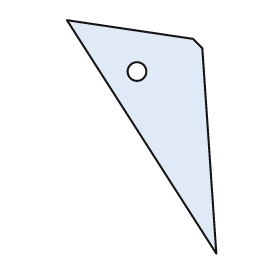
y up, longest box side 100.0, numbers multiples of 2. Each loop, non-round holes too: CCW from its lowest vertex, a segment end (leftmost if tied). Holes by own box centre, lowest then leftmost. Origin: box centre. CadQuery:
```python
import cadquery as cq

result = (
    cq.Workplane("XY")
    .moveTo(32.0, -50.0)
    .lineTo(26.0, 38.0)
    .lineTo(22.0, 42.0)
    .lineTo(-32.0, 50.0)
    .close()
    .moveTo(-2.0, 28.0)
    .circle(4.0)
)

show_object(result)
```